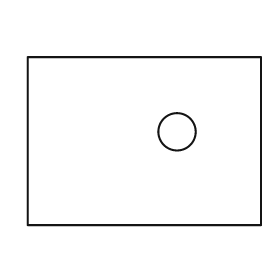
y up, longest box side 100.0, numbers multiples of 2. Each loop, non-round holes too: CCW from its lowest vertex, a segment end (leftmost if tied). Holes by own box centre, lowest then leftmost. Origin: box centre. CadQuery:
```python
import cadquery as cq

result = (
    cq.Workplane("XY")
    .moveTo(-50.0, -36.0)
    .lineTo(50.0, -36.0)
    .lineTo(50.0, 36.0)
    .lineTo(-50.0, 36.0)
    .close()
    .moveTo(14.0, 4.0)
    .circle(8.0)
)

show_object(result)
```